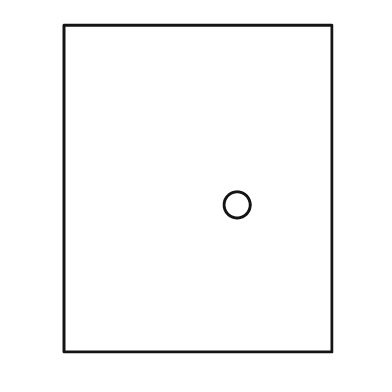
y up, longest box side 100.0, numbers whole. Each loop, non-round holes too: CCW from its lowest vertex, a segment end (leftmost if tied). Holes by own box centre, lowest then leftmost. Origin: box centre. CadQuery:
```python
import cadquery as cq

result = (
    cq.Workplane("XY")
    .moveTo(-41.0, -50.0)
    .lineTo(41.0, -50.0)
    .lineTo(41.0, 50.0)
    .lineTo(-41.0, 50.0)
    .close()
    .moveTo(12.0, -5.0)
    .circle(4.0)
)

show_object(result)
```